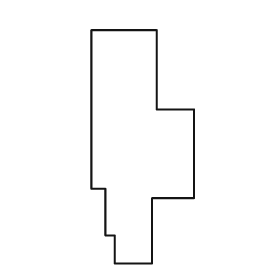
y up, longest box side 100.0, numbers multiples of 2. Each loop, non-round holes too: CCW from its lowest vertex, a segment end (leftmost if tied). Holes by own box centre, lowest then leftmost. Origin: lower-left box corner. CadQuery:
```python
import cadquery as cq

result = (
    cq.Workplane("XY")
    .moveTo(10.0, 0.0)
    .lineTo(26.0, 0.0)
    .lineTo(26.0, 28.0)
    .lineTo(44.0, 28.0)
    .lineTo(44.0, 66.0)
    .lineTo(28.0, 66.0)
    .lineTo(28.0, 100.0)
    .lineTo(0.0, 100.0)
    .lineTo(0.0, 32.0)
    .lineTo(6.0, 32.0)
    .lineTo(6.0, 12.0)
    .lineTo(10.0, 12.0)
    .close()
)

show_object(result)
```